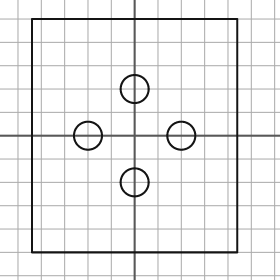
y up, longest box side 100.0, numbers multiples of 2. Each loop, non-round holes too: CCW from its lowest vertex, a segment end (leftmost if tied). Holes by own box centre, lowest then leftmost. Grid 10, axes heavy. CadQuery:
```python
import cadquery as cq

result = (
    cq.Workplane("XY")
    .moveTo(-44.0, -50.0)
    .lineTo(44.0, -50.0)
    .lineTo(44.0, 50.0)
    .lineTo(-44.0, 50.0)
    .close()
    .moveTo(0.0, -20.0)
    .circle(6.0)
    .moveTo(-20.0, 0.0)
    .circle(6.0)
    .moveTo(20.0, 0.0)
    .circle(6.0)
    .moveTo(0.0, 20.0)
    .circle(6.0)
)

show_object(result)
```